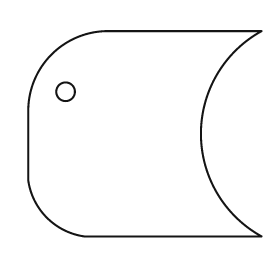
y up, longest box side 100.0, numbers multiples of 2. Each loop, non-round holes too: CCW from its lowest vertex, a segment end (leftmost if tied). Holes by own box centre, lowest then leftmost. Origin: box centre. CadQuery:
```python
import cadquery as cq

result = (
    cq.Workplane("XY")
    .moveTo(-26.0, -44.0)
    .lineTo(50.0, -44.0)
    .threePointArc((24.0, 0.0), (50.0, 44.0))
    .lineTo(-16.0, 44.0)
    .threePointArc((-40.0, 34.0), (-50.0, 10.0))
    .lineTo(-50.0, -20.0)
    .threePointArc((-42.0, -36.0), (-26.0, -44.0))
    .close()
    .moveTo(-34.0, 18.0)
    .circle(4.0)
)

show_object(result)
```